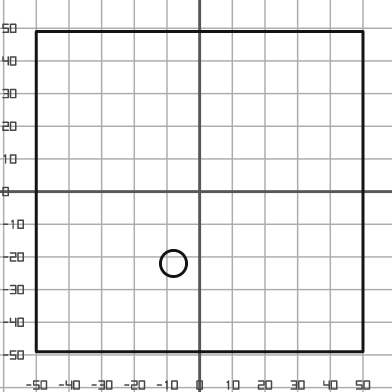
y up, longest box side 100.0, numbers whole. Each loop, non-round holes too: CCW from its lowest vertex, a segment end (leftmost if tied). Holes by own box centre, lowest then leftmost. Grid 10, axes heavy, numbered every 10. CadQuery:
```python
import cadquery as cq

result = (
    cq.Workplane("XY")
    .moveTo(-50.0, -49.0)
    .lineTo(50.0, -49.0)
    .lineTo(50.0, 49.0)
    .lineTo(-50.0, 49.0)
    .close()
    .moveTo(-8.0, -22.0)
    .circle(4.0)
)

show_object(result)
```